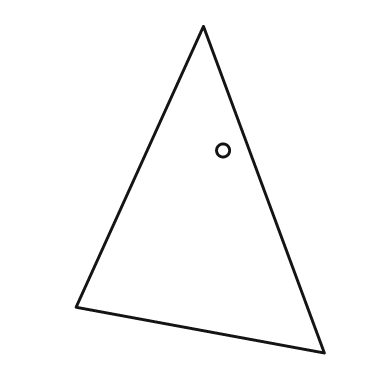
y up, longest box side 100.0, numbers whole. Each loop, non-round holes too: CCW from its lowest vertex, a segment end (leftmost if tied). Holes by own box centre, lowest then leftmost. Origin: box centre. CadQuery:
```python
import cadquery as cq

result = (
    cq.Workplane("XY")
    .moveTo(38.0, -50.0)
    .lineTo(1.0, 50.0)
    .lineTo(-38.0, -36.0)
    .close()
    .moveTo(7.0, 12.0)
    .circle(2.0)
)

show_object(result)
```